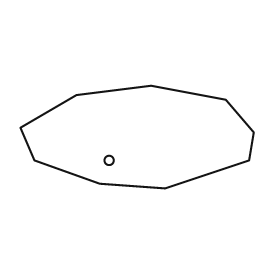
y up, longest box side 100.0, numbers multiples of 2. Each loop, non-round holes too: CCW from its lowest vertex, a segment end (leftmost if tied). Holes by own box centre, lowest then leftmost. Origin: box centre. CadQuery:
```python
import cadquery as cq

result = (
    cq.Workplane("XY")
    .moveTo(12.0, -22.0)
    .lineTo(48.0, -10.0)
    .lineTo(50.0, 2.0)
    .lineTo(38.0, 16.0)
    .lineTo(6.0, 22.0)
    .lineTo(-26.0, 18.0)
    .lineTo(-50.0, 4.0)
    .lineTo(-44.0, -10.0)
    .lineTo(-16.0, -20.0)
    .close()
    .moveTo(-12.0, -10.0)
    .circle(2.0)
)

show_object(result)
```